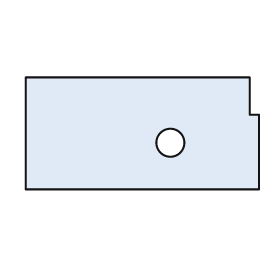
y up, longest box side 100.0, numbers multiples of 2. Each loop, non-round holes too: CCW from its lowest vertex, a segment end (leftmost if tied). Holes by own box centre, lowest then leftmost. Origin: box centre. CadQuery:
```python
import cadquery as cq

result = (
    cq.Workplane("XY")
    .moveTo(-50.0, -24.0)
    .lineTo(50.0, -24.0)
    .lineTo(50.0, 8.0)
    .lineTo(46.0, 8.0)
    .lineTo(46.0, 24.0)
    .lineTo(-50.0, 24.0)
    .close()
    .moveTo(12.0, -4.0)
    .circle(6.0)
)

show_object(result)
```